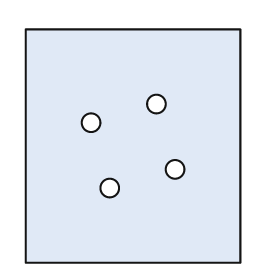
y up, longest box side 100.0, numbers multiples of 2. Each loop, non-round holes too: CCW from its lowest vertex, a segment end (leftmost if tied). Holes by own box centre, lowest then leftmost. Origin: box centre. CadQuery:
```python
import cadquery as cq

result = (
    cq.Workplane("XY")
    .moveTo(-46.0, -50.0)
    .lineTo(46.0, -50.0)
    .lineTo(46.0, 50.0)
    .lineTo(-46.0, 50.0)
    .close()
    .moveTo(-10.0, -18.0)
    .circle(4.0)
    .moveTo(18.0, -10.0)
    .circle(4.0)
    .moveTo(-18.0, 10.0)
    .circle(4.0)
    .moveTo(10.0, 18.0)
    .circle(4.0)
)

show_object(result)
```